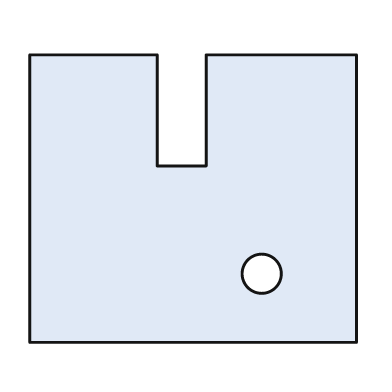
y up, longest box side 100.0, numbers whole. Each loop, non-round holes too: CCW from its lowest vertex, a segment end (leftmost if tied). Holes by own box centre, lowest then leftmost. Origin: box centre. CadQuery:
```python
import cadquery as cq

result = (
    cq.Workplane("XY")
    .moveTo(-50.0, -44.0)
    .lineTo(50.0, -44.0)
    .lineTo(50.0, 44.0)
    .lineTo(4.0, 44.0)
    .lineTo(4.0, 10.0)
    .lineTo(-11.0, 10.0)
    .lineTo(-11.0, 44.0)
    .lineTo(-50.0, 44.0)
    .close()
    .moveTo(21.0, -23.0)
    .circle(6.0)
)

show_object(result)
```